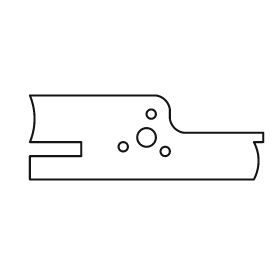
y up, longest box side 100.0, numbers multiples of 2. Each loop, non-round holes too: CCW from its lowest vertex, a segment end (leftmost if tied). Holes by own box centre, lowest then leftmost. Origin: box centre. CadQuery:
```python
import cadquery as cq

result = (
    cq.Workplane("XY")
    .moveTo(-50.0, -18.0)
    .lineTo(46.0, -18.0)
    .threePointArc((48.0, -10.0), (46.0, -2.0))
    .lineTo(50.0, -2.0)
    .lineTo(50.0, 2.0)
    .lineTo(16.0, 2.0)
    .threePointArc((12.0, 4.0), (10.0, 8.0))
    .lineTo(10.0, 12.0)
    .threePointArc((8.0, 16.0), (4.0, 18.0))
    .lineTo(-50.0, 18.0)
    .threePointArc((-48.0, 8.0), (-50.0, -2.0))
    .lineTo(-28.0, -2.0)
    .lineTo(-28.0, -8.0)
    .lineTo(-50.0, -8.0)
    .close()
    .moveTo(8.0, -6.0)
    .circle(2.0)
    .moveTo(-10.0, -4.0)
    .circle(2.0)
    .moveTo(0.0, 0.0)
    .circle(4.0)
    .moveTo(2.0, 10.0)
    .circle(2.0)
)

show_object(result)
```